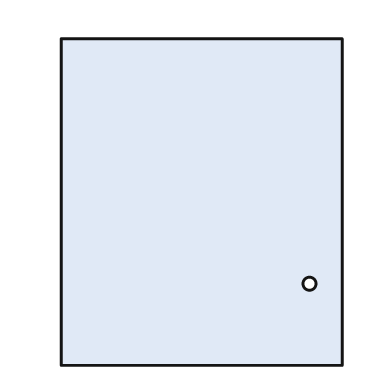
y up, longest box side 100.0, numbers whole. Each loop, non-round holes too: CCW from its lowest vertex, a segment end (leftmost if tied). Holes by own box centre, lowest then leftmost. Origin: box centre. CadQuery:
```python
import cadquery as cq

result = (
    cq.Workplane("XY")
    .moveTo(-43.0, -50.0)
    .lineTo(43.0, -50.0)
    .lineTo(43.0, 50.0)
    .lineTo(-43.0, 50.0)
    .close()
    .moveTo(33.0, -25.0)
    .circle(2.0)
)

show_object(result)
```